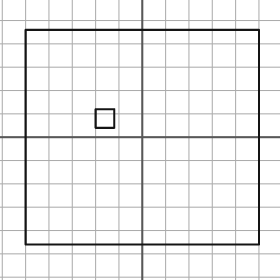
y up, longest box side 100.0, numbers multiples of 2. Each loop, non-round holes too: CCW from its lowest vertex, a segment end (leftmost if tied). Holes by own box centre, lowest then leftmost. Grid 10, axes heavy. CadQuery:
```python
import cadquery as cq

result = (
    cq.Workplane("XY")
    .moveTo(-50.0, -46.0)
    .lineTo(50.0, -46.0)
    .lineTo(50.0, 46.0)
    .lineTo(-50.0, 46.0)
    .close()
    .moveTo(-20.0, 4.0)
    .lineTo(-12.0, 4.0)
    .lineTo(-12.0, 12.0)
    .lineTo(-20.0, 12.0)
    .close()
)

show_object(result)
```